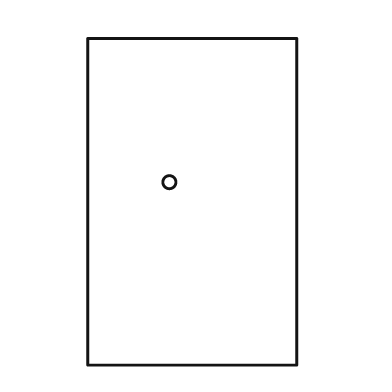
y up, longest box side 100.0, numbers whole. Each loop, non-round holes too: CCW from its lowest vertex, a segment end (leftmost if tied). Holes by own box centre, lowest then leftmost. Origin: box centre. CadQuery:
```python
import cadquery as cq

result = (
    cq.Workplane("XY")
    .moveTo(-32.0, -50.0)
    .lineTo(32.0, -50.0)
    .lineTo(32.0, 50.0)
    .lineTo(-32.0, 50.0)
    .close()
    .moveTo(-7.0, 6.0)
    .circle(2.0)
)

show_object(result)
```